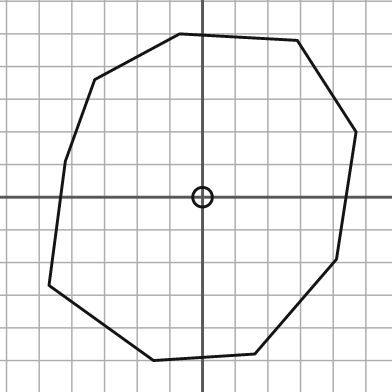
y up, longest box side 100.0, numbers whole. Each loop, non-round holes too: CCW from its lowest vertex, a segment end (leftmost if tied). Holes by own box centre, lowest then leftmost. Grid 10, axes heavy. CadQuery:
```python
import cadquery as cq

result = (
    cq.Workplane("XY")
    .moveTo(-15.0, -50.0)
    .lineTo(16.0, -48.0)
    .lineTo(41.0, -19.0)
    .lineTo(47.0, 20.0)
    .lineTo(29.0, 48.0)
    .lineTo(-7.0, 50.0)
    .lineTo(-33.0, 36.0)
    .lineTo(-42.0, 11.0)
    .lineTo(-47.0, -27.0)
    .close()
    .moveTo(0.0, 0.0)
    .circle(3.0)
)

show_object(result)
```